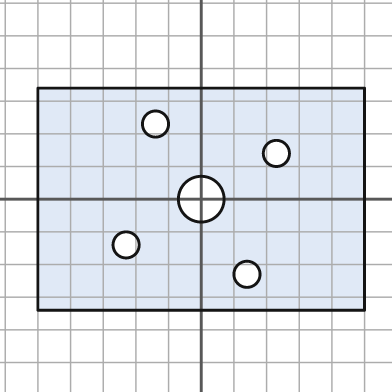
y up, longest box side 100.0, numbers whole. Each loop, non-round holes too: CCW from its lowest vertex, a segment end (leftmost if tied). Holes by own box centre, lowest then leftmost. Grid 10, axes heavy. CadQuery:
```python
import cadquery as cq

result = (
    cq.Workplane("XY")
    .moveTo(-50.0, -34.0)
    .lineTo(50.0, -34.0)
    .lineTo(50.0, 34.0)
    .lineTo(-50.0, 34.0)
    .close()
    .moveTo(14.0, -23.0)
    .circle(4.0)
    .moveTo(-23.0, -14.0)
    .circle(4.0)
    .moveTo(0.0, 0.0)
    .circle(7.0)
    .moveTo(23.0, 14.0)
    .circle(4.0)
    .moveTo(-14.0, 23.0)
    .circle(4.0)
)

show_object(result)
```